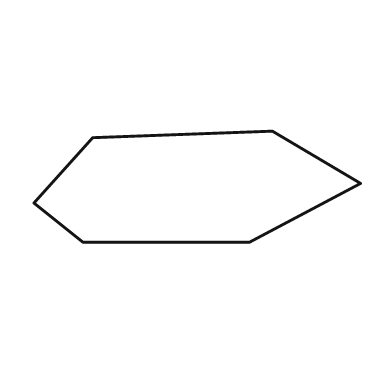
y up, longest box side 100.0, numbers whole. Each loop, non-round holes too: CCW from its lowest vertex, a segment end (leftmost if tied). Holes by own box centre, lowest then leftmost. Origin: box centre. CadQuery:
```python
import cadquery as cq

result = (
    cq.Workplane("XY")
    .moveTo(-35.0, -17.0)
    .lineTo(16.0, -17.0)
    .lineTo(50.0, 1.0)
    .lineTo(23.0, 17.0)
    .lineTo(-32.0, 15.0)
    .lineTo(-50.0, -5.0)
    .close()
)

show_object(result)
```